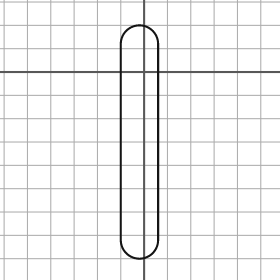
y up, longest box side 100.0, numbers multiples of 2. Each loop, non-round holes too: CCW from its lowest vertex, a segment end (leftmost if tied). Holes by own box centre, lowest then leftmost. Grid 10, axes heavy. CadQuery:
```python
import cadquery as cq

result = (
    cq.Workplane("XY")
    .moveTo(-10.0, -72.0)
    .threePointArc((-2.0, -80.0), (6.0, -72.0))
    .lineTo(6.0, 12.0)
    .threePointArc((-2.0, 20.0), (-10.0, 12.0))
    .close()
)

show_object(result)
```